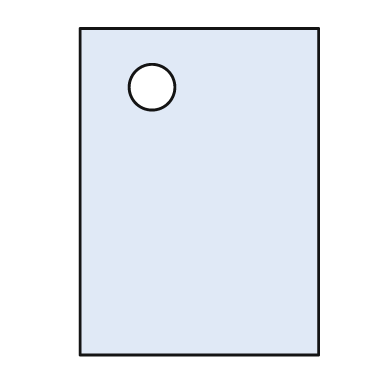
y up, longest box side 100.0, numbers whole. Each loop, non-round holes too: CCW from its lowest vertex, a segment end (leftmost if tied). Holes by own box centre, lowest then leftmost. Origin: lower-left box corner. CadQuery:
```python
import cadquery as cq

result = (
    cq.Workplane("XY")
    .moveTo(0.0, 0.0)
    .lineTo(73.0, 0.0)
    .lineTo(73.0, 100.0)
    .lineTo(0.0, 100.0)
    .close()
    .moveTo(22.0, 82.0)
    .circle(7.0)
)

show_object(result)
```